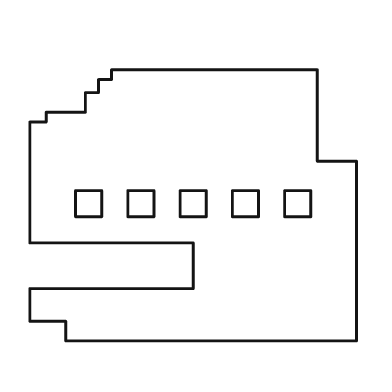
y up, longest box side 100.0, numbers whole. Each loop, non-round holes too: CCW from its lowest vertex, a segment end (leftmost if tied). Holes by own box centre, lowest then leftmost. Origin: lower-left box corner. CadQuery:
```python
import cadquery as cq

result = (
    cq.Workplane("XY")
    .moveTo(11.0, 0.0)
    .lineTo(100.0, 0.0)
    .lineTo(100.0, 55.0)
    .lineTo(88.0, 55.0)
    .lineTo(88.0, 83.0)
    .lineTo(25.0, 83.0)
    .lineTo(25.0, 80.0)
    .lineTo(21.0, 80.0)
    .lineTo(21.0, 76.0)
    .lineTo(17.0, 76.0)
    .lineTo(17.0, 70.0)
    .lineTo(5.0, 70.0)
    .lineTo(5.0, 67.0)
    .lineTo(0.0, 67.0)
    .lineTo(0.0, 30.0)
    .lineTo(50.0, 30.0)
    .lineTo(50.0, 16.0)
    .lineTo(0.0, 16.0)
    .lineTo(0.0, 6.0)
    .lineTo(11.0, 6.0)
    .close()
    .moveTo(14.0, 38.0)
    .lineTo(22.0, 38.0)
    .lineTo(22.0, 46.0)
    .lineTo(14.0, 46.0)
    .close()
    .moveTo(30.0, 38.0)
    .lineTo(38.0, 38.0)
    .lineTo(38.0, 46.0)
    .lineTo(30.0, 46.0)
    .close()
    .moveTo(46.0, 38.0)
    .lineTo(54.0, 38.0)
    .lineTo(54.0, 46.0)
    .lineTo(46.0, 46.0)
    .close()
    .moveTo(62.0, 38.0)
    .lineTo(70.0, 38.0)
    .lineTo(70.0, 46.0)
    .lineTo(62.0, 46.0)
    .close()
    .moveTo(78.0, 38.0)
    .lineTo(86.0, 38.0)
    .lineTo(86.0, 46.0)
    .lineTo(78.0, 46.0)
    .close()
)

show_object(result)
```